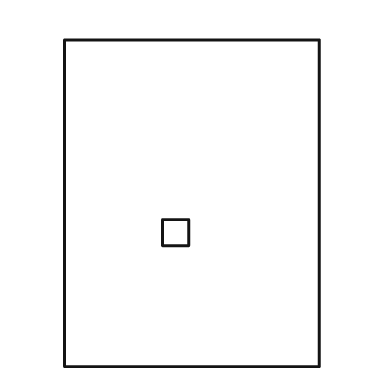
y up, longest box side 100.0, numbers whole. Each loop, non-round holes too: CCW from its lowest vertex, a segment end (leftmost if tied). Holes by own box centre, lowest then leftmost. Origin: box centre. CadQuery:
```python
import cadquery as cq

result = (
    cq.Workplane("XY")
    .moveTo(-39.0, -50.0)
    .lineTo(39.0, -50.0)
    .lineTo(39.0, 50.0)
    .lineTo(-39.0, 50.0)
    .close()
    .moveTo(-9.0, -13.0)
    .lineTo(-1.0, -13.0)
    .lineTo(-1.0, -5.0)
    .lineTo(-9.0, -5.0)
    .close()
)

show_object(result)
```